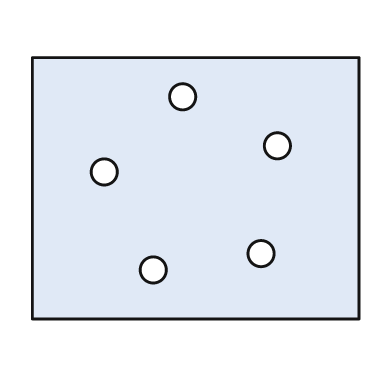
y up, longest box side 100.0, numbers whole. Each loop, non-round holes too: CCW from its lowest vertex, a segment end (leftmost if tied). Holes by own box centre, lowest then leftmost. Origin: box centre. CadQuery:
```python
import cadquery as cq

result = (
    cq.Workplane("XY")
    .moveTo(-50.0, -40.0)
    .lineTo(50.0, -40.0)
    .lineTo(50.0, 40.0)
    .lineTo(-50.0, 40.0)
    .close()
    .moveTo(-13.0, -25.0)
    .circle(4.0)
    .moveTo(20.0, -20.0)
    .circle(4.0)
    .moveTo(-28.0, 5.0)
    .circle(4.0)
    .moveTo(25.0, 13.0)
    .circle(4.0)
    .moveTo(-4.0, 28.0)
    .circle(4.0)
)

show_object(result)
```